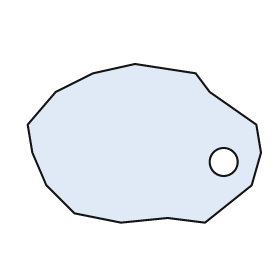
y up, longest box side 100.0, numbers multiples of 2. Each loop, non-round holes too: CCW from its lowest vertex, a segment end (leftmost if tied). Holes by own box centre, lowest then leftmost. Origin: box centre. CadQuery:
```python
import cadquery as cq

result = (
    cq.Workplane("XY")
    .moveTo(-10.0, -34.0)
    .lineTo(10.0, -32.0)
    .lineTo(26.0, -34.0)
    .lineTo(46.0, -18.0)
    .lineTo(50.0, -4.0)
    .lineTo(48.0, 8.0)
    .lineTo(28.0, 22.0)
    .lineTo(22.0, 30.0)
    .lineTo(-4.0, 34.0)
    .lineTo(-22.0, 30.0)
    .lineTo(-38.0, 22.0)
    .lineTo(-50.0, 8.0)
    .lineTo(-48.0, -4.0)
    .lineTo(-42.0, -18.0)
    .lineTo(-30.0, -30.0)
    .close()
    .moveTo(34.0, -8.0)
    .circle(6.0)
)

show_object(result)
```